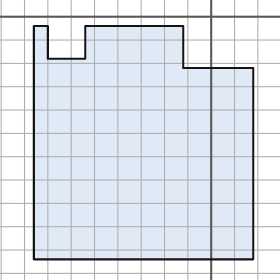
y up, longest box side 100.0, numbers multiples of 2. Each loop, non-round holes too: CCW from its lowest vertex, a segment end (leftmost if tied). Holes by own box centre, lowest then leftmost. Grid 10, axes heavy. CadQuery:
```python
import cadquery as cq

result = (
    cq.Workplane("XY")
    .moveTo(-76.0, -104.0)
    .lineTo(18.0, -104.0)
    .lineTo(18.0, -22.0)
    .lineTo(-12.0, -22.0)
    .lineTo(-12.0, -4.0)
    .lineTo(-54.0, -4.0)
    .lineTo(-54.0, -18.0)
    .lineTo(-70.0, -18.0)
    .lineTo(-70.0, -4.0)
    .lineTo(-76.0, -4.0)
    .close()
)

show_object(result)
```